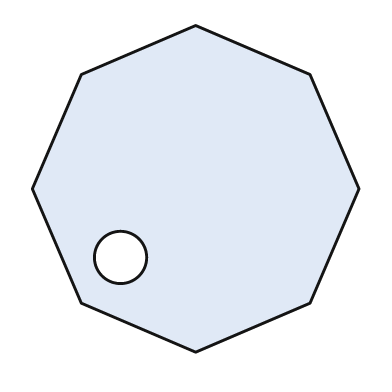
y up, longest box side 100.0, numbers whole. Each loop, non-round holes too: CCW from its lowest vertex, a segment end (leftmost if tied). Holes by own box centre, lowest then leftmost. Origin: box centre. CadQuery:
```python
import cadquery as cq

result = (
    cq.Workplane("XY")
    .moveTo(0.0, -50.0)
    .lineTo(35.0, -35.0)
    .lineTo(50.0, 0.0)
    .lineTo(35.0, 35.0)
    .lineTo(0.0, 50.0)
    .lineTo(-35.0, 35.0)
    .lineTo(-50.0, 0.0)
    .lineTo(-35.0, -35.0)
    .close()
    .moveTo(-23.0, -21.0)
    .circle(8.0)
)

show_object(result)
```